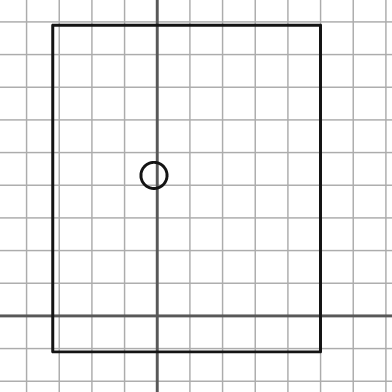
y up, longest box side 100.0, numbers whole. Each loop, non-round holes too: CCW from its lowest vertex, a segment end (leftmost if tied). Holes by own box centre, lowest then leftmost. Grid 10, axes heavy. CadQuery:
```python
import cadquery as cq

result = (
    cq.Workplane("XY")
    .moveTo(-32.0, -11.0)
    .lineTo(50.0, -11.0)
    .lineTo(50.0, 89.0)
    .lineTo(-32.0, 89.0)
    .close()
    .moveTo(-1.0, 43.0)
    .circle(4.0)
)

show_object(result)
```